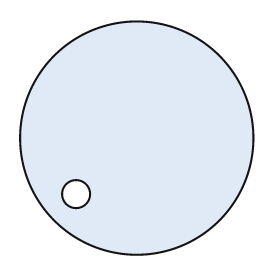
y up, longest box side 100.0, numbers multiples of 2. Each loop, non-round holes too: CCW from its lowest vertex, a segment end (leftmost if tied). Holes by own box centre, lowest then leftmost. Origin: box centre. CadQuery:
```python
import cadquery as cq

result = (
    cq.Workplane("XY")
    .moveTo(0.0, 0.0)
    .circle(50.0)
    .moveTo(-26.0, -24.0)
    .circle(6.0)
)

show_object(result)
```